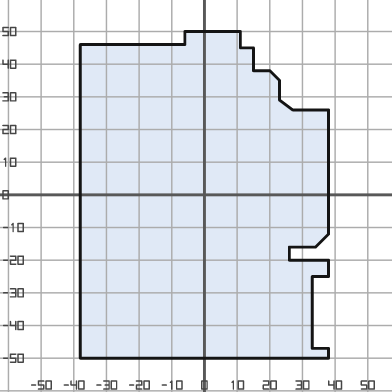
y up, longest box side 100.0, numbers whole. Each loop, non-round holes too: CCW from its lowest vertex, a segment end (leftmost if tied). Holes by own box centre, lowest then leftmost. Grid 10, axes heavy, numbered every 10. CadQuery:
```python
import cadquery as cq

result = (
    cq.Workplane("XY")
    .moveTo(-38.0, -50.0)
    .lineTo(38.0, -50.0)
    .lineTo(38.0, -47.0)
    .lineTo(33.0, -47.0)
    .lineTo(33.0, -25.0)
    .lineTo(38.0, -25.0)
    .lineTo(38.0, -20.0)
    .lineTo(26.0, -20.0)
    .lineTo(26.0, -16.0)
    .lineTo(34.0, -16.0)
    .lineTo(38.0, -12.0)
    .lineTo(38.0, 26.0)
    .lineTo(27.0, 26.0)
    .lineTo(23.0, 29.0)
    .lineTo(23.0, 35.0)
    .lineTo(20.0, 38.0)
    .lineTo(15.0, 38.0)
    .lineTo(15.0, 45.0)
    .lineTo(11.0, 45.0)
    .lineTo(11.0, 50.0)
    .lineTo(-6.0, 50.0)
    .lineTo(-6.0, 46.0)
    .lineTo(-38.0, 46.0)
    .close()
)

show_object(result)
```